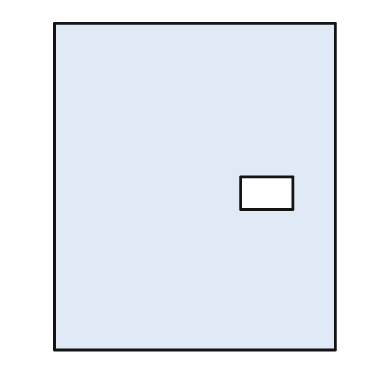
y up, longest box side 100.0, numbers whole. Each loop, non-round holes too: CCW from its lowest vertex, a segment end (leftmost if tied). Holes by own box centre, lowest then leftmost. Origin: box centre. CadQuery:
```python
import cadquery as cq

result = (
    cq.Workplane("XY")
    .moveTo(-43.0, -50.0)
    .lineTo(43.0, -50.0)
    .lineTo(43.0, 50.0)
    .lineTo(-43.0, 50.0)
    .close()
    .moveTo(14.0, -7.0)
    .lineTo(30.0, -7.0)
    .lineTo(30.0, 3.0)
    .lineTo(14.0, 3.0)
    .close()
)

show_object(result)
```